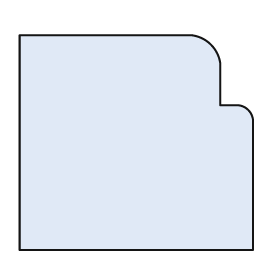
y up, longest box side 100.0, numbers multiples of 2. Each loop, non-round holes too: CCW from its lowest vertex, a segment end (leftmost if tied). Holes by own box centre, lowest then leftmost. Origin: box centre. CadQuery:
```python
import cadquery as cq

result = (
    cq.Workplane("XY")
    .moveTo(-50.0, -46.0)
    .lineTo(50.0, -46.0)
    .lineTo(50.0, 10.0)
    .threePointArc((48.0, 14.0), (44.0, 16.0))
    .lineTo(36.0, 16.0)
    .lineTo(36.0, 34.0)
    .threePointArc((32.0, 42.0), (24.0, 46.0))
    .lineTo(-50.0, 46.0)
    .close()
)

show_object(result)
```